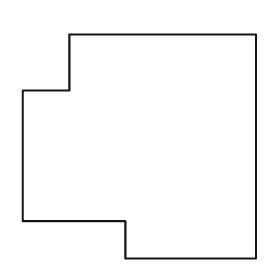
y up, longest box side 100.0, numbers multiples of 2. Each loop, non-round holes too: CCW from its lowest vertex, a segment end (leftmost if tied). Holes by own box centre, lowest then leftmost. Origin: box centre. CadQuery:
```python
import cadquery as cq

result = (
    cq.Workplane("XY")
    .moveTo(-6.0, -48.0)
    .lineTo(50.0, -48.0)
    .lineTo(50.0, 48.0)
    .lineTo(-30.0, 48.0)
    .lineTo(-30.0, 24.0)
    .lineTo(-50.0, 24.0)
    .lineTo(-50.0, -32.0)
    .lineTo(-6.0, -32.0)
    .close()
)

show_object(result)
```